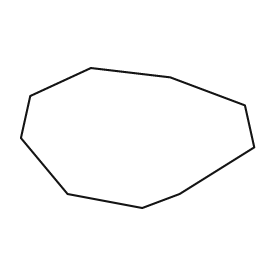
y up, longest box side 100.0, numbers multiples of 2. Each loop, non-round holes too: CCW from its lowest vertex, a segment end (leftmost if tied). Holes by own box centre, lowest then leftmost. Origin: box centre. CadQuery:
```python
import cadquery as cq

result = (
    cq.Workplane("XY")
    .moveTo(2.0, -30.0)
    .lineTo(18.0, -24.0)
    .lineTo(50.0, -4.0)
    .lineTo(46.0, 14.0)
    .lineTo(14.0, 26.0)
    .lineTo(-20.0, 30.0)
    .lineTo(-46.0, 18.0)
    .lineTo(-50.0, 0.0)
    .lineTo(-30.0, -24.0)
    .close()
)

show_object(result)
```